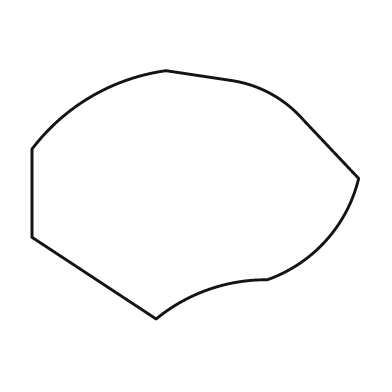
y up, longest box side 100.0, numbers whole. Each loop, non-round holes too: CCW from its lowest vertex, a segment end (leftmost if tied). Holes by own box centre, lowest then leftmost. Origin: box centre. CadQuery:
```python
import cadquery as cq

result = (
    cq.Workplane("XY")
    .moveTo(-12.0, -38.0)
    .threePointArc((4.0, -29.0), (22.0, -26.0))
    .threePointArc((40.0, -14.0), (50.0, 5.0))
    .lineTo(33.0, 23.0)
    .threePointArc((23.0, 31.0), (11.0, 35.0))
    .lineTo(-9.0, 38.0)
    .threePointArc((-32.0, 30.0), (-50.0, 14.0))
    .lineTo(-50.0, -13.0)
    .close()
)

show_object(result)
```